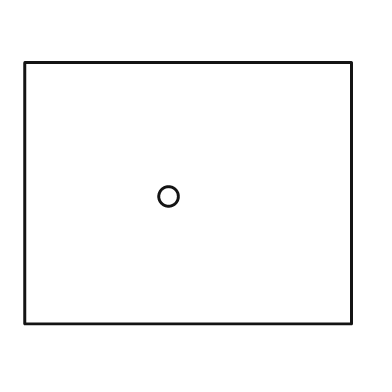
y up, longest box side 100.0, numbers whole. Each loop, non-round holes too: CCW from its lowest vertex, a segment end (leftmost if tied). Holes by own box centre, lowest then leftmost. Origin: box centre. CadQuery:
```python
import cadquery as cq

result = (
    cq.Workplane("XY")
    .moveTo(-50.0, -40.0)
    .lineTo(50.0, -40.0)
    .lineTo(50.0, 40.0)
    .lineTo(-50.0, 40.0)
    .close()
    .moveTo(-6.0, -1.0)
    .circle(3.0)
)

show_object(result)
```